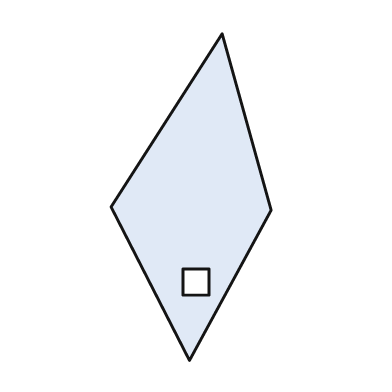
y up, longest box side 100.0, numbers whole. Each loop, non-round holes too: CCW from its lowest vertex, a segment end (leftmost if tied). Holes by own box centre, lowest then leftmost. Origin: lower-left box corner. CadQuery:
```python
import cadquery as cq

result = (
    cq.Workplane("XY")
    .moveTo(24.0, 0.0)
    .lineTo(49.0, 46.0)
    .lineTo(34.0, 100.0)
    .lineTo(0.0, 47.0)
    .close()
    .moveTo(22.0, 20.0)
    .lineTo(30.0, 20.0)
    .lineTo(30.0, 28.0)
    .lineTo(22.0, 28.0)
    .close()
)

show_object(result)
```